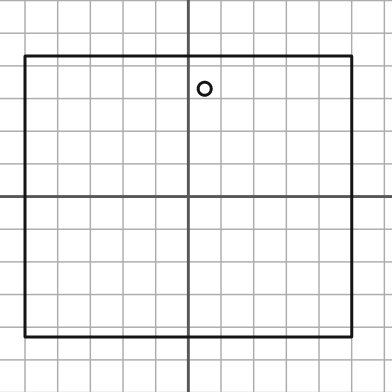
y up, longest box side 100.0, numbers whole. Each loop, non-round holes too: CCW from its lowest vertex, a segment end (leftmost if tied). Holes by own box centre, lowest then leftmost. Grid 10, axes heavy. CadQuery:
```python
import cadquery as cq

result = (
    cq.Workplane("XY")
    .moveTo(-50.0, -43.0)
    .lineTo(50.0, -43.0)
    .lineTo(50.0, 43.0)
    .lineTo(-50.0, 43.0)
    .close()
    .moveTo(5.0, 33.0)
    .circle(2.0)
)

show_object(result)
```